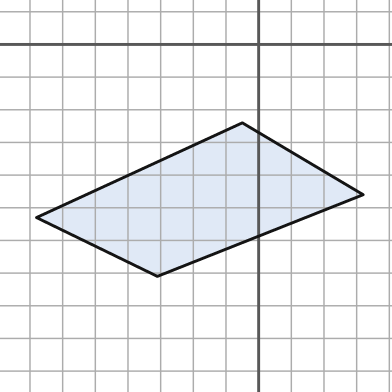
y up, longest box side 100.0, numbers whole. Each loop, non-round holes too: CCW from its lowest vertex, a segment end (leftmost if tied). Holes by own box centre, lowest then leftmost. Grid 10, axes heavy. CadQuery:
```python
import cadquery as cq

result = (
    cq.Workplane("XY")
    .moveTo(-31.0, -71.0)
    .lineTo(32.0, -46.0)
    .lineTo(-5.0, -24.0)
    .lineTo(-68.0, -53.0)
    .close()
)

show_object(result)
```